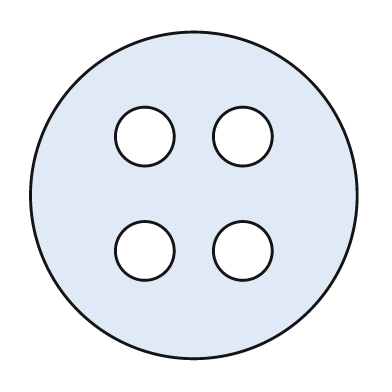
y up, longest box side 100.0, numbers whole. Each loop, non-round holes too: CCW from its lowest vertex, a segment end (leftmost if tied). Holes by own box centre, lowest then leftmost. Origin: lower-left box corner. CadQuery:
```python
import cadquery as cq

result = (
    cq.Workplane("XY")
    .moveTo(50.0, 50.0)
    .circle(50.0)
    .moveTo(35.0, 33.0)
    .circle(9.0)
    .moveTo(65.0, 33.0)
    .circle(9.0)
    .moveTo(35.0, 68.0)
    .circle(9.0)
    .moveTo(65.0, 68.0)
    .circle(9.0)
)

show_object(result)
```